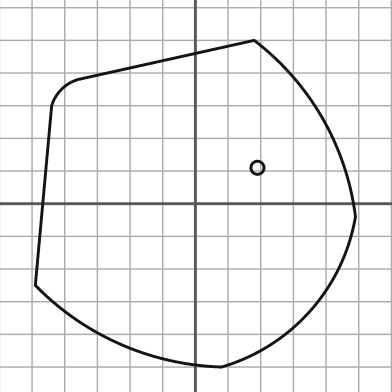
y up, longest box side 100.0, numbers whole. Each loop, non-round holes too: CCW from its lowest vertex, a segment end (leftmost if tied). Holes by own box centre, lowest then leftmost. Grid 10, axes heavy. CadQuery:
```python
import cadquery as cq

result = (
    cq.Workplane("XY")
    .moveTo(8.0, -50.0)
    .threePointArc((35.0, -33.0), (49.0, -4.0))
    .threePointArc((39.0, 26.0), (18.0, 50.0))
    .lineTo(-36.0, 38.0)
    .threePointArc((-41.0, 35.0), (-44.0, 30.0))
    .lineTo(-49.0, -25.0)
    .threePointArc((-23.0, -43.0), (8.0, -50.0))
    .close()
    .moveTo(19.0, 11.0)
    .circle(2.0)
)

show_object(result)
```